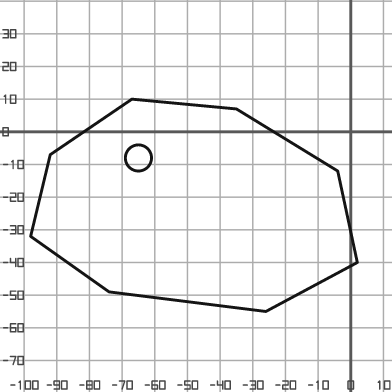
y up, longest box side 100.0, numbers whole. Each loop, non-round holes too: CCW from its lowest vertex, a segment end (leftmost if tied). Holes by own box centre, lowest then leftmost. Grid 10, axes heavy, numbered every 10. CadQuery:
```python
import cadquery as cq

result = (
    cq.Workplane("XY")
    .moveTo(-26.0, -55.0)
    .lineTo(2.0, -40.0)
    .lineTo(-4.0, -12.0)
    .lineTo(-35.0, 7.0)
    .lineTo(-67.0, 10.0)
    .lineTo(-92.0, -7.0)
    .lineTo(-98.0, -32.0)
    .lineTo(-74.0, -49.0)
    .close()
    .moveTo(-65.0, -8.0)
    .circle(4.0)
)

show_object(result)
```